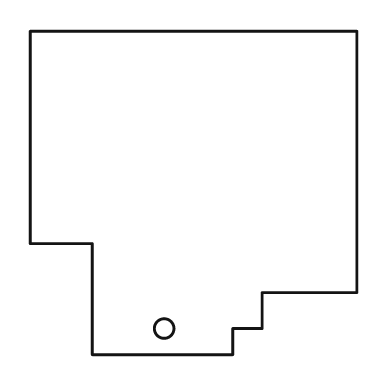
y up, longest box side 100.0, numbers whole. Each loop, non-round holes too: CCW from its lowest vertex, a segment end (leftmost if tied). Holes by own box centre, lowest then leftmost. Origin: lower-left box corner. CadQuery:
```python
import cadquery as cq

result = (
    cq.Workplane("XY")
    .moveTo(19.0, 0.0)
    .lineTo(62.0, 0.0)
    .lineTo(62.0, 8.0)
    .lineTo(71.0, 8.0)
    .lineTo(71.0, 19.0)
    .lineTo(100.0, 19.0)
    .lineTo(100.0, 99.0)
    .lineTo(0.0, 99.0)
    .lineTo(0.0, 34.0)
    .lineTo(19.0, 34.0)
    .close()
    .moveTo(41.0, 8.0)
    .circle(3.0)
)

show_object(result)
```